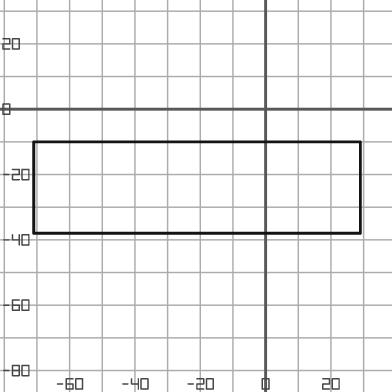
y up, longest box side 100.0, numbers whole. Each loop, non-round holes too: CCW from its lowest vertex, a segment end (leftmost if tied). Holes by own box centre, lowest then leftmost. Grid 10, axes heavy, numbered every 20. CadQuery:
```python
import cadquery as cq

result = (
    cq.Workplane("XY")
    .moveTo(-71.0, -38.0)
    .lineTo(29.0, -38.0)
    .lineTo(29.0, -10.0)
    .lineTo(-71.0, -10.0)
    .close()
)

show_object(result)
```